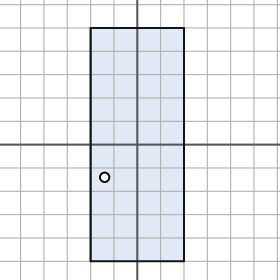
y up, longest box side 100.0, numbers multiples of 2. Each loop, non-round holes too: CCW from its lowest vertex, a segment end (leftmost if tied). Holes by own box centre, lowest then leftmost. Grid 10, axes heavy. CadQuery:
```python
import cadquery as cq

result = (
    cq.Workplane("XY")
    .moveTo(-20.0, -50.0)
    .lineTo(20.0, -50.0)
    .lineTo(20.0, 50.0)
    .lineTo(-20.0, 50.0)
    .close()
    .moveTo(-14.0, -14.0)
    .circle(2.0)
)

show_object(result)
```